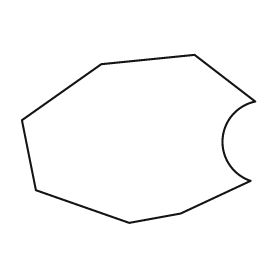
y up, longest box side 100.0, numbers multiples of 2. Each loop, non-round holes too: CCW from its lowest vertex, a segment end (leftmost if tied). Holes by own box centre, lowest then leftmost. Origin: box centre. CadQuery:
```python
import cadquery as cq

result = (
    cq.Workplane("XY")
    .moveTo(-4.0, -36.0)
    .lineTo(18.0, -32.0)
    .lineTo(48.0, -18.0)
    .threePointArc((36.0, 0.0), (50.0, 16.0))
    .lineTo(24.0, 36.0)
    .lineTo(-16.0, 32.0)
    .lineTo(-50.0, 8.0)
    .lineTo(-44.0, -22.0)
    .close()
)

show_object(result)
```